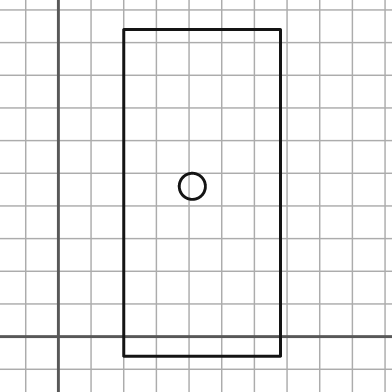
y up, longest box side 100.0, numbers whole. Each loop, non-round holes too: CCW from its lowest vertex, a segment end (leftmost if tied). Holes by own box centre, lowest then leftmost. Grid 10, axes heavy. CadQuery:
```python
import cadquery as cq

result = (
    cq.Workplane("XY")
    .moveTo(20.0, -6.0)
    .lineTo(68.0, -6.0)
    .lineTo(68.0, 94.0)
    .lineTo(20.0, 94.0)
    .close()
    .moveTo(41.0, 46.0)
    .circle(4.0)
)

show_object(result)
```